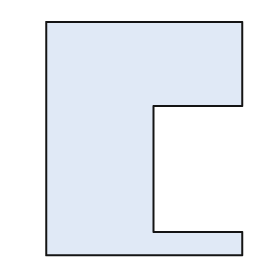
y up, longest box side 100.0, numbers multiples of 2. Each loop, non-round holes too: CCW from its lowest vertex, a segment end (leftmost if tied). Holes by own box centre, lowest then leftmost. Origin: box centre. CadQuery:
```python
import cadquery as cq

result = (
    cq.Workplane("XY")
    .moveTo(-42.0, -50.0)
    .lineTo(42.0, -50.0)
    .lineTo(42.0, -40.0)
    .lineTo(4.0, -40.0)
    .lineTo(4.0, 14.0)
    .lineTo(42.0, 14.0)
    .lineTo(42.0, 50.0)
    .lineTo(-42.0, 50.0)
    .close()
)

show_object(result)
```